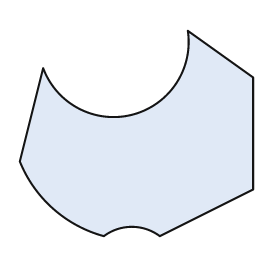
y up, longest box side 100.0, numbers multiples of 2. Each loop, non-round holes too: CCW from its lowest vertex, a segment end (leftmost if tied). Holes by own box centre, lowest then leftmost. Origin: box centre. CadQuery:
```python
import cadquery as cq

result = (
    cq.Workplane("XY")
    .moveTo(-14.0, -44.0)
    .threePointArc((-2.0, -40.0), (10.0, -44.0))
    .lineTo(50.0, -24.0)
    .lineTo(50.0, 24.0)
    .lineTo(22.0, 44.0)
    .threePointArc((-2.0, 8.0), (-40.0, 28.0))
    .lineTo(-50.0, -12.0)
    .threePointArc((-36.0, -32.0), (-14.0, -44.0))
    .close()
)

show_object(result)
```